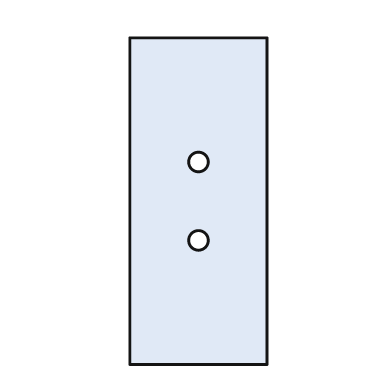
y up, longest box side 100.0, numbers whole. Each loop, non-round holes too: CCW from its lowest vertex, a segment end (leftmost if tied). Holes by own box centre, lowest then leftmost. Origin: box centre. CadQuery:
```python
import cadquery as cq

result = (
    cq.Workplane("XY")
    .moveTo(-21.0, -50.0)
    .lineTo(21.0, -50.0)
    .lineTo(21.0, 50.0)
    .lineTo(-21.0, 50.0)
    .close()
    .moveTo(0.0, -12.0)
    .circle(3.0)
    .moveTo(0.0, 12.0)
    .circle(3.0)
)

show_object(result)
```